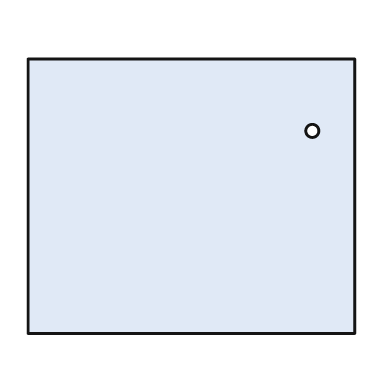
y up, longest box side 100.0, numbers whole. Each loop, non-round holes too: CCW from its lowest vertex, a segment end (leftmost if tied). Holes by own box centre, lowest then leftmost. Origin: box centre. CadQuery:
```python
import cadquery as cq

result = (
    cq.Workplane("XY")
    .moveTo(-50.0, -42.0)
    .lineTo(50.0, -42.0)
    .lineTo(50.0, 42.0)
    .lineTo(-50.0, 42.0)
    .close()
    .moveTo(37.0, 20.0)
    .circle(2.0)
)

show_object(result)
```